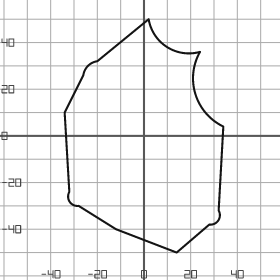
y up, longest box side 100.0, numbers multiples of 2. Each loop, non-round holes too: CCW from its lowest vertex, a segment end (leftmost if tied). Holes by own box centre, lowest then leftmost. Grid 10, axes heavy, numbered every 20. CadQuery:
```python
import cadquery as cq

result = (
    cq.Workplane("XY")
    .moveTo(14.0, -50.0)
    .lineTo(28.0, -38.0)
    .threePointArc((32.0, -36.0), (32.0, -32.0))
    .lineTo(34.0, 4.0)
    .threePointArc((22.0, 18.0), (24.0, 36.0))
    .threePointArc((10.0, 38.0), (2.0, 50.0))
    .lineTo(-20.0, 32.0)
    .threePointArc((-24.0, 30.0), (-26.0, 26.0))
    .lineTo(-34.0, 10.0)
    .lineTo(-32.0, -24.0)
    .threePointArc((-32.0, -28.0), (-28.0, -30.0))
    .lineTo(-12.0, -40.0)
    .close()
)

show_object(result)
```